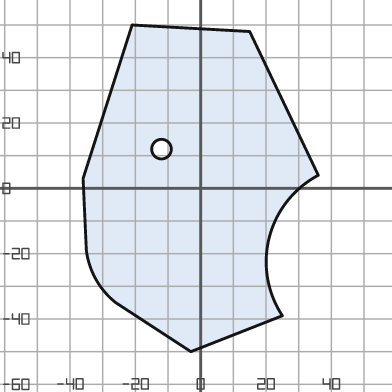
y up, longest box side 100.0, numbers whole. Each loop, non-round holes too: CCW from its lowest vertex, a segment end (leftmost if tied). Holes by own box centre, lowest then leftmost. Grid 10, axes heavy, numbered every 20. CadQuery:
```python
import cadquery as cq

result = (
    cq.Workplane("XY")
    .moveTo(-3.0, -50.0)
    .lineTo(25.0, -39.0)
    .threePointArc((21.0, -15.0), (36.0, 4.0))
    .lineTo(15.0, 48.0)
    .lineTo(-21.0, 50.0)
    .lineTo(-36.0, 3.0)
    .lineTo(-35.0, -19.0)
    .threePointArc((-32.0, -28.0), (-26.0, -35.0))
    .close()
    .moveTo(-12.0, 12.0)
    .circle(3.0)
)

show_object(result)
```